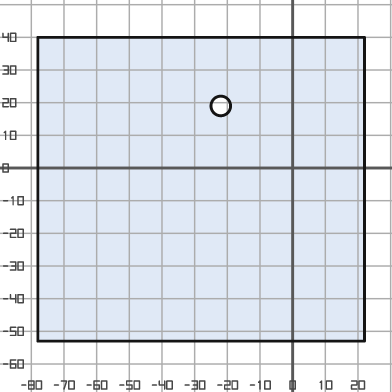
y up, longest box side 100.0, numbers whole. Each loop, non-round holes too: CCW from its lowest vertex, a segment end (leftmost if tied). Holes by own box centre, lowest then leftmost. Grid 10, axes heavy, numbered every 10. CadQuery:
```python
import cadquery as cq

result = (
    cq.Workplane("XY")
    .moveTo(-78.0, -53.0)
    .lineTo(22.0, -53.0)
    .lineTo(22.0, 40.0)
    .lineTo(-78.0, 40.0)
    .close()
    .moveTo(-22.0, 19.0)
    .circle(3.0)
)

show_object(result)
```